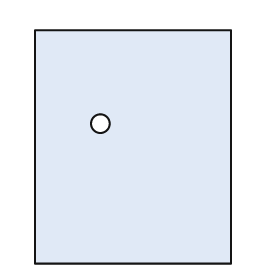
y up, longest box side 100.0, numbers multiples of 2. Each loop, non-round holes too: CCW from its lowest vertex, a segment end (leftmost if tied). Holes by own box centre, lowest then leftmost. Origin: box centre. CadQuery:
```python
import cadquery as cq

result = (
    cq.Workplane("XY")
    .moveTo(-42.0, -50.0)
    .lineTo(42.0, -50.0)
    .lineTo(42.0, 50.0)
    .lineTo(-42.0, 50.0)
    .close()
    .moveTo(-14.0, 10.0)
    .circle(4.0)
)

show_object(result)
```